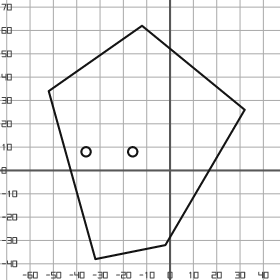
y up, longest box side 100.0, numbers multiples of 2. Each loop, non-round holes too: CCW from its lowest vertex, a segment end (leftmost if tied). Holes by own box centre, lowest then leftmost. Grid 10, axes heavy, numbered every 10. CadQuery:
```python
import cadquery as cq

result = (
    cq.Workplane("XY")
    .moveTo(-32.0, -38.0)
    .lineTo(-2.0, -32.0)
    .lineTo(32.0, 26.0)
    .lineTo(-12.0, 62.0)
    .lineTo(-52.0, 34.0)
    .close()
    .moveTo(-36.0, 8.0)
    .circle(2.0)
    .moveTo(-16.0, 8.0)
    .circle(2.0)
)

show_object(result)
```